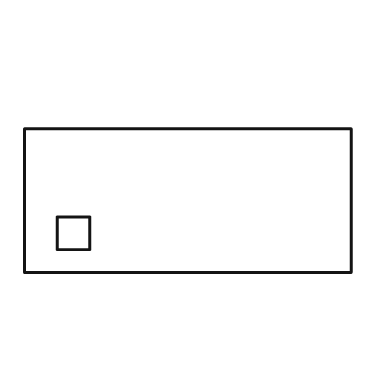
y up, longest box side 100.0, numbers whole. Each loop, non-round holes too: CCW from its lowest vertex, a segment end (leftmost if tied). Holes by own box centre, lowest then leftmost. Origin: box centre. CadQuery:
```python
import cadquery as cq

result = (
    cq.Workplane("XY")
    .moveTo(-50.0, -22.0)
    .lineTo(50.0, -22.0)
    .lineTo(50.0, 22.0)
    .lineTo(-50.0, 22.0)
    .close()
    .moveTo(-40.0, -15.0)
    .lineTo(-30.0, -15.0)
    .lineTo(-30.0, -5.0)
    .lineTo(-40.0, -5.0)
    .close()
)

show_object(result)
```